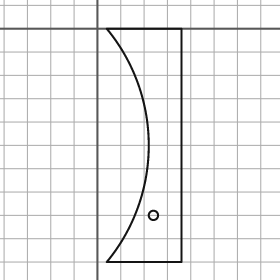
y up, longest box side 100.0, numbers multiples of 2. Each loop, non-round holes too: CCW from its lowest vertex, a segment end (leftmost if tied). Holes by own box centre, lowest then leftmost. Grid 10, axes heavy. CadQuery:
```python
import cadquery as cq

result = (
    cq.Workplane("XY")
    .moveTo(4.0, -100.0)
    .lineTo(36.0, -100.0)
    .lineTo(36.0, 0.0)
    .lineTo(4.0, 0.0)
    .threePointArc((22.0, -50.0), (4.0, -100.0))
    .close()
    .moveTo(24.0, -80.0)
    .circle(2.0)
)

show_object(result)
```